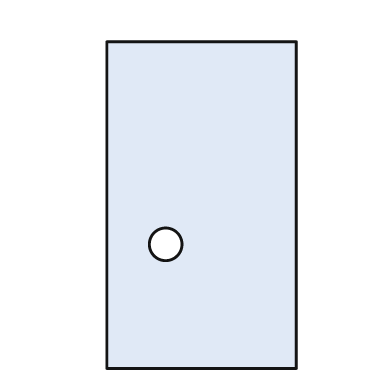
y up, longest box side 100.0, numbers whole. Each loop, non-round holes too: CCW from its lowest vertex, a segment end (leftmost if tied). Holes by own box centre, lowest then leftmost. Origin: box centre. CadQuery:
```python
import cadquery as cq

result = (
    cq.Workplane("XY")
    .moveTo(-29.0, -50.0)
    .lineTo(29.0, -50.0)
    .lineTo(29.0, 50.0)
    .lineTo(-29.0, 50.0)
    .close()
    .moveTo(-11.0, -12.0)
    .circle(5.0)
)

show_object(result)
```